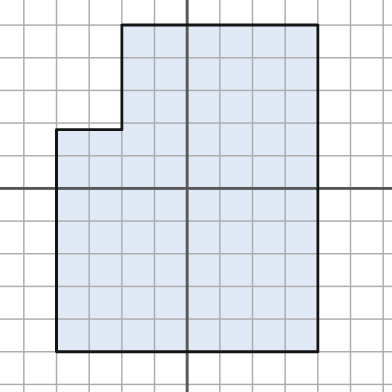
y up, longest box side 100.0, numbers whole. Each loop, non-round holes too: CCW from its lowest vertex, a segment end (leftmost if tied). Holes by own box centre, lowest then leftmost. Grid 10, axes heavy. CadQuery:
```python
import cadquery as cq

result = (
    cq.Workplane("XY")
    .moveTo(-40.0, -50.0)
    .lineTo(40.0, -50.0)
    .lineTo(40.0, 50.0)
    .lineTo(-20.0, 50.0)
    .lineTo(-20.0, 18.0)
    .lineTo(-40.0, 18.0)
    .close()
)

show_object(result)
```